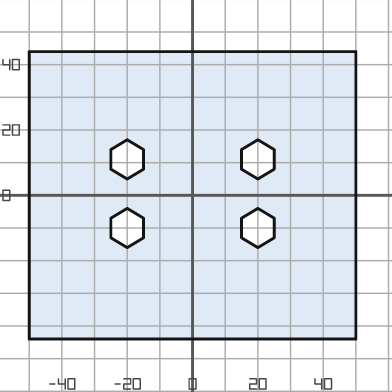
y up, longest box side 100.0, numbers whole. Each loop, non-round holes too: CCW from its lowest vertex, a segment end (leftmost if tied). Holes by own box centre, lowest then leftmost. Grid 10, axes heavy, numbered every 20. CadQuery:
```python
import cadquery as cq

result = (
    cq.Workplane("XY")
    .moveTo(-50.0, -44.0)
    .lineTo(50.0, -44.0)
    .lineTo(50.0, 44.0)
    .lineTo(-50.0, 44.0)
    .close()
    .moveTo(-20.0, -16.0)
    .lineTo(-15.0, -13.0)
    .lineTo(-15.0, -7.0)
    .lineTo(-20.0, -4.0)
    .lineTo(-25.0, -7.0)
    .lineTo(-25.0, -13.0)
    .close()
    .moveTo(20.0, -16.0)
    .lineTo(25.0, -13.0)
    .lineTo(25.0, -7.0)
    .lineTo(20.0, -4.0)
    .lineTo(15.0, -7.0)
    .lineTo(15.0, -13.0)
    .close()
    .moveTo(-20.0, 5.0)
    .lineTo(-15.0, 8.0)
    .lineTo(-15.0, 14.0)
    .lineTo(-20.0, 17.0)
    .lineTo(-25.0, 14.0)
    .lineTo(-25.0, 8.0)
    .close()
    .moveTo(20.0, 5.0)
    .lineTo(25.0, 8.0)
    .lineTo(25.0, 14.0)
    .lineTo(20.0, 17.0)
    .lineTo(15.0, 14.0)
    .lineTo(15.0, 8.0)
    .close()
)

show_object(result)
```